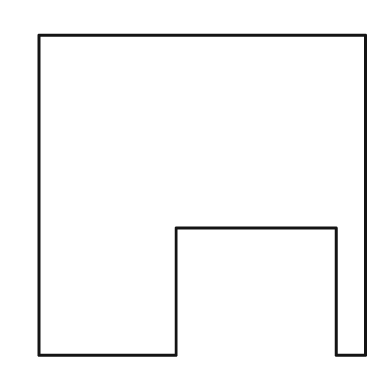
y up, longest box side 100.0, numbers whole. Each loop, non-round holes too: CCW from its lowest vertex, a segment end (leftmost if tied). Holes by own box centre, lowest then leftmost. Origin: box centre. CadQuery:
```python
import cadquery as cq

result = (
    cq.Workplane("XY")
    .moveTo(-50.0, -49.0)
    .lineTo(-8.0, -49.0)
    .lineTo(-8.0, -10.0)
    .lineTo(41.0, -10.0)
    .lineTo(41.0, -49.0)
    .lineTo(50.0, -49.0)
    .lineTo(50.0, 49.0)
    .lineTo(-50.0, 49.0)
    .close()
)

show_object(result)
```